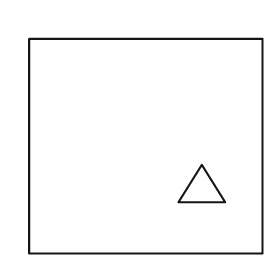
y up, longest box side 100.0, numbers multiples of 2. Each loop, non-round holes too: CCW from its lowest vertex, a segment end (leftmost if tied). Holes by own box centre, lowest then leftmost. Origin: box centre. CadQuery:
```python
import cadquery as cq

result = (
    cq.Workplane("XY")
    .moveTo(-50.0, -46.0)
    .lineTo(50.0, -46.0)
    .lineTo(50.0, 46.0)
    .lineTo(-50.0, 46.0)
    .close()
    .moveTo(14.0, -24.0)
    .lineTo(34.0, -24.0)
    .lineTo(24.0, -8.0)
    .close()
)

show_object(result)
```